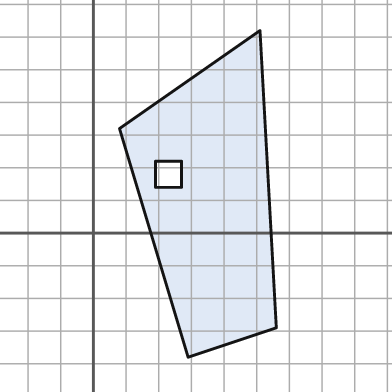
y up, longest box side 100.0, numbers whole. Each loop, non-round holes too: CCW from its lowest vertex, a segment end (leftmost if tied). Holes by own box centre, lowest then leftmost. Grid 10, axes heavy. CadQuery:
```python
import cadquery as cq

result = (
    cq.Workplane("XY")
    .moveTo(29.0, -38.0)
    .lineTo(56.0, -29.0)
    .lineTo(51.0, 62.0)
    .lineTo(8.0, 32.0)
    .close()
    .moveTo(19.0, 14.0)
    .lineTo(27.0, 14.0)
    .lineTo(27.0, 22.0)
    .lineTo(19.0, 22.0)
    .close()
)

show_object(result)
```